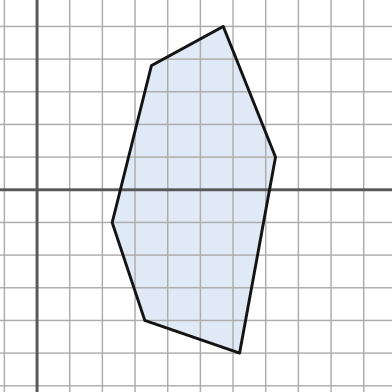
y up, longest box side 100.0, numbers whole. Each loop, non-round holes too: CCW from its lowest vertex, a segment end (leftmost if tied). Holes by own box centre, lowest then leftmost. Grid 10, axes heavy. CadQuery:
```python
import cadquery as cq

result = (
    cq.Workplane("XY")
    .moveTo(62.0, -50.0)
    .lineTo(73.0, 10.0)
    .lineTo(57.0, 50.0)
    .lineTo(35.0, 38.0)
    .lineTo(23.0, -10.0)
    .lineTo(33.0, -40.0)
    .close()
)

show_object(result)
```